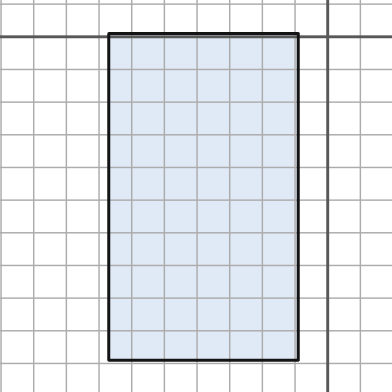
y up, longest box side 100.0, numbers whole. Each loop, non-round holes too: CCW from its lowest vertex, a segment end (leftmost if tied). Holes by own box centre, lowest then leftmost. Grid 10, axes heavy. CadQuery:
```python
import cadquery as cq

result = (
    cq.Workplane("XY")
    .moveTo(-67.0, -99.0)
    .lineTo(-9.0, -99.0)
    .lineTo(-9.0, 1.0)
    .lineTo(-67.0, 1.0)
    .close()
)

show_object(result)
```